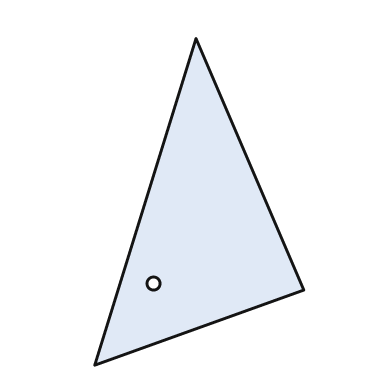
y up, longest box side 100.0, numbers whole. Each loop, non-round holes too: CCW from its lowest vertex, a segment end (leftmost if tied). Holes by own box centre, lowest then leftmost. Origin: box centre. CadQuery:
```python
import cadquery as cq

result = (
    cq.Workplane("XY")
    .moveTo(-32.0, -50.0)
    .lineTo(32.0, -27.0)
    .lineTo(-1.0, 50.0)
    .close()
    .moveTo(-14.0, -25.0)
    .circle(2.0)
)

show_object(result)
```